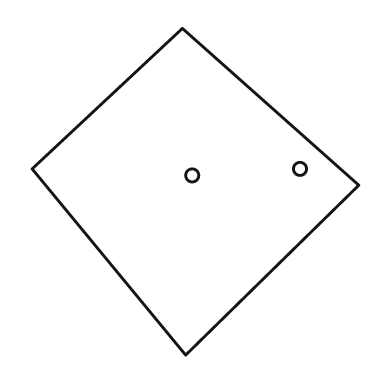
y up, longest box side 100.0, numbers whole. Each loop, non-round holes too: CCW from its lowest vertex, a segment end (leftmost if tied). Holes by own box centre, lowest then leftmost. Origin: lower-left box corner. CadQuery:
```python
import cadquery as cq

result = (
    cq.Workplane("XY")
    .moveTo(47.0, 0.0)
    .lineTo(100.0, 52.0)
    .lineTo(46.0, 100.0)
    .lineTo(0.0, 57.0)
    .close()
    .moveTo(49.0, 55.0)
    .circle(2.0)
    .moveTo(82.0, 57.0)
    .circle(2.0)
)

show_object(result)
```